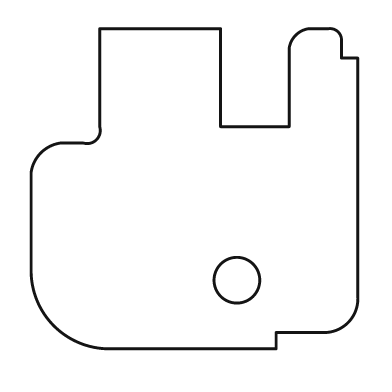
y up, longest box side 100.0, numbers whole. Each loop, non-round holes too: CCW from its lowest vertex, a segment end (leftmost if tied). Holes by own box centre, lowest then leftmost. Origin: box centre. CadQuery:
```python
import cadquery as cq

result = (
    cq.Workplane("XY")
    .moveTo(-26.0, -49.0)
    .lineTo(25.0, -49.0)
    .lineTo(25.0, -44.0)
    .lineTo(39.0, -44.0)
    .threePointArc((47.0, -41.0), (50.0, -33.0))
    .lineTo(50.0, 40.0)
    .lineTo(45.0, 40.0)
    .lineTo(45.0, 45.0)
    .threePointArc((44.0, 48.0), (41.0, 49.0))
    .lineTo(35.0, 49.0)
    .threePointArc((31.0, 47.0), (29.0, 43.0))
    .lineTo(29.0, 19.0)
    .lineTo(8.0, 19.0)
    .lineTo(8.0, 49.0)
    .lineTo(-29.0, 49.0)
    .lineTo(-29.0, 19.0)
    .threePointArc((-30.0, 15.0), (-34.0, 14.0))
    .lineTo(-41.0, 14.0)
    .threePointArc((-47.0, 11.0), (-50.0, 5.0))
    .lineTo(-50.0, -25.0)
    .threePointArc((-43.0, -42.0), (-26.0, -49.0))
    .close()
    .moveTo(13.0, -28.0)
    .circle(7.0)
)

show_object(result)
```